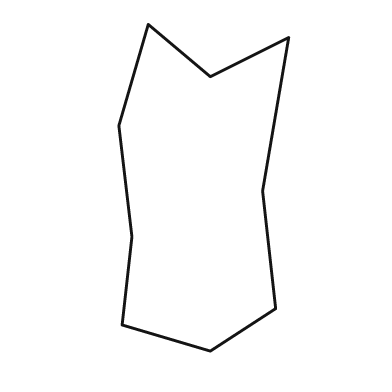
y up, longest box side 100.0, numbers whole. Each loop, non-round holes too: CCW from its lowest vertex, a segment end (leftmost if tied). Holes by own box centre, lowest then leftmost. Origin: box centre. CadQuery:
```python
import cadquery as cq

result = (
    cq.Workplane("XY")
    .moveTo(2.0, -50.0)
    .lineTo(22.0, -37.0)
    .lineTo(18.0, -1.0)
    .lineTo(26.0, 46.0)
    .lineTo(2.0, 34.0)
    .lineTo(-17.0, 50.0)
    .lineTo(-26.0, 19.0)
    .lineTo(-22.0, -15.0)
    .lineTo(-25.0, -42.0)
    .close()
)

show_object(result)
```